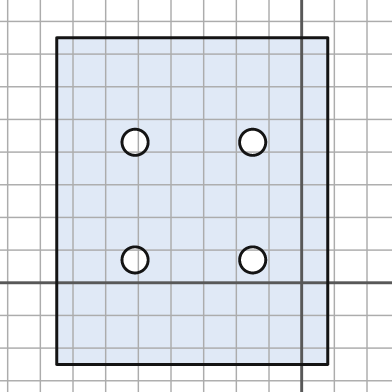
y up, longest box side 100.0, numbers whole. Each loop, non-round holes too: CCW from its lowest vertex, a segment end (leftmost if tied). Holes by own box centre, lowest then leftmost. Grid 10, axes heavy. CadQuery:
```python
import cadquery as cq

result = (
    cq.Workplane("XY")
    .moveTo(-75.0, -25.0)
    .lineTo(8.0, -25.0)
    .lineTo(8.0, 75.0)
    .lineTo(-75.0, 75.0)
    .close()
    .moveTo(-51.0, 7.0)
    .circle(4.0)
    .moveTo(-15.0, 7.0)
    .circle(4.0)
    .moveTo(-51.0, 43.0)
    .circle(4.0)
    .moveTo(-15.0, 43.0)
    .circle(4.0)
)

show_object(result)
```